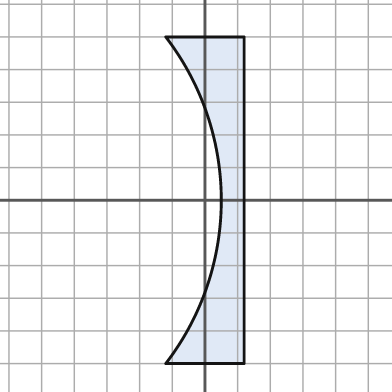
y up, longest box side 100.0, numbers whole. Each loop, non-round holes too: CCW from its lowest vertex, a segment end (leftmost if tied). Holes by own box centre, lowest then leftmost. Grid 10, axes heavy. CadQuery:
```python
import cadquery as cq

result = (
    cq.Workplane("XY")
    .moveTo(-12.0, -50.0)
    .lineTo(12.0, -50.0)
    .lineTo(12.0, 50.0)
    .lineTo(-12.0, 50.0)
    .threePointArc((5.0, 0.0), (-12.0, -50.0))
    .close()
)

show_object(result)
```